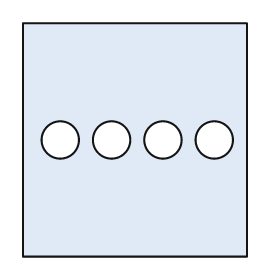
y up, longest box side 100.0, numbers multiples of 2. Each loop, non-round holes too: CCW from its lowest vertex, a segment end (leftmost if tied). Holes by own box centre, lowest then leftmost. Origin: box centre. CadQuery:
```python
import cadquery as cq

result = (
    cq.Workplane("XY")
    .moveTo(-48.0, -50.0)
    .lineTo(48.0, -50.0)
    .lineTo(48.0, 50.0)
    .lineTo(-48.0, 50.0)
    .close()
    .moveTo(-32.0, 0.0)
    .circle(8.0)
    .moveTo(-10.0, 0.0)
    .circle(8.0)
    .moveTo(12.0, 0.0)
    .circle(8.0)
    .moveTo(34.0, 0.0)
    .circle(8.0)
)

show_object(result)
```